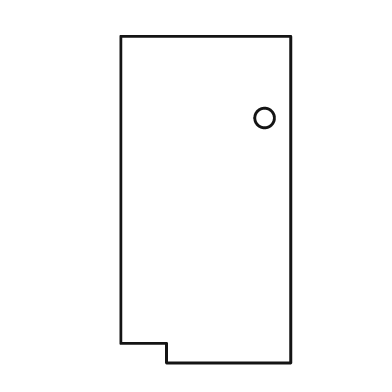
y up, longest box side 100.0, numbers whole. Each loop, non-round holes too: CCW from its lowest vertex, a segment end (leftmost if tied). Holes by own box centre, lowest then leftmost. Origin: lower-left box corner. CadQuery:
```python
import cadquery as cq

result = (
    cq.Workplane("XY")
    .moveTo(14.0, 0.0)
    .lineTo(52.0, 0.0)
    .lineTo(52.0, 100.0)
    .lineTo(0.0, 100.0)
    .lineTo(0.0, 6.0)
    .lineTo(14.0, 6.0)
    .close()
    .moveTo(44.0, 75.0)
    .circle(3.0)
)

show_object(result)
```